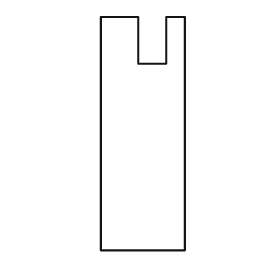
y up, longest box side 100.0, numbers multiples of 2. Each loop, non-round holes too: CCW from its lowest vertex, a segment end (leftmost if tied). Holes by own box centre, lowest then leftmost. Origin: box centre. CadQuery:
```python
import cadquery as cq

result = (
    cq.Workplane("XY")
    .moveTo(-18.0, -50.0)
    .lineTo(18.0, -50.0)
    .lineTo(18.0, 50.0)
    .lineTo(10.0, 50.0)
    .lineTo(10.0, 30.0)
    .lineTo(-2.0, 30.0)
    .lineTo(-2.0, 50.0)
    .lineTo(-18.0, 50.0)
    .close()
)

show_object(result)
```